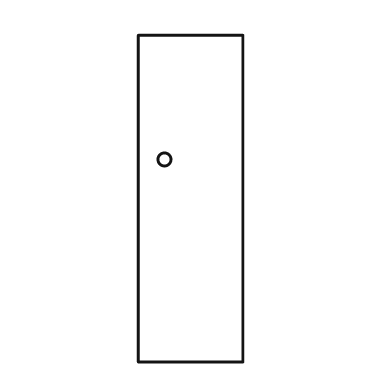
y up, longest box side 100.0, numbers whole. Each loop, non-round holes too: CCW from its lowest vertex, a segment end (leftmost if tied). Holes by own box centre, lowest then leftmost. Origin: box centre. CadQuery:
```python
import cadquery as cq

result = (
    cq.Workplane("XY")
    .moveTo(-16.0, -50.0)
    .lineTo(16.0, -50.0)
    .lineTo(16.0, 50.0)
    .lineTo(-16.0, 50.0)
    .close()
    .moveTo(-8.0, 12.0)
    .circle(2.0)
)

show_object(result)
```